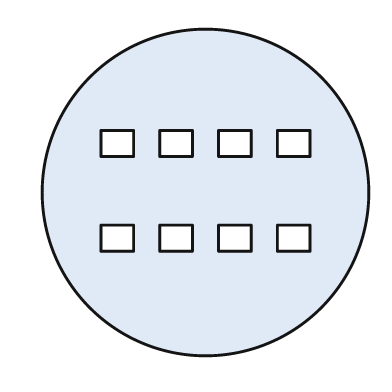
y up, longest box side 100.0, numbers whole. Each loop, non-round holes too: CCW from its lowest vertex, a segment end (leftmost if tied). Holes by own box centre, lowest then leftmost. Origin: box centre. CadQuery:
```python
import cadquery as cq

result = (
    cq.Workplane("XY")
    .moveTo(0.0, 0.0)
    .circle(50.0)
    .moveTo(-32.0, -18.0)
    .lineTo(-22.0, -18.0)
    .lineTo(-22.0, -10.0)
    .lineTo(-32.0, -10.0)
    .close()
    .moveTo(-14.0, -18.0)
    .lineTo(-4.0, -18.0)
    .lineTo(-4.0, -10.0)
    .lineTo(-14.0, -10.0)
    .close()
    .moveTo(4.0, -18.0)
    .lineTo(14.0, -18.0)
    .lineTo(14.0, -10.0)
    .lineTo(4.0, -10.0)
    .close()
    .moveTo(22.0, -18.0)
    .lineTo(32.0, -18.0)
    .lineTo(32.0, -10.0)
    .lineTo(22.0, -10.0)
    .close()
    .moveTo(-32.0, 11.0)
    .lineTo(-22.0, 11.0)
    .lineTo(-22.0, 19.0)
    .lineTo(-32.0, 19.0)
    .close()
    .moveTo(-14.0, 11.0)
    .lineTo(-4.0, 11.0)
    .lineTo(-4.0, 19.0)
    .lineTo(-14.0, 19.0)
    .close()
    .moveTo(4.0, 11.0)
    .lineTo(14.0, 11.0)
    .lineTo(14.0, 19.0)
    .lineTo(4.0, 19.0)
    .close()
    .moveTo(22.0, 11.0)
    .lineTo(32.0, 11.0)
    .lineTo(32.0, 19.0)
    .lineTo(22.0, 19.0)
    .close()
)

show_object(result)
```